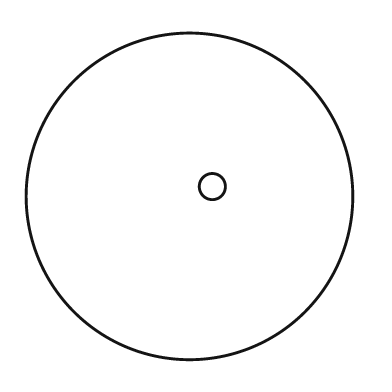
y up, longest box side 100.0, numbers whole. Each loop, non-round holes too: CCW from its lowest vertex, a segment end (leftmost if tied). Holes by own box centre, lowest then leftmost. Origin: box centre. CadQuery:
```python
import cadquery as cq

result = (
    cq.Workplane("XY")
    .moveTo(0.0, 0.0)
    .circle(50.0)
    .moveTo(7.0, 3.0)
    .circle(4.0)
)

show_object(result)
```